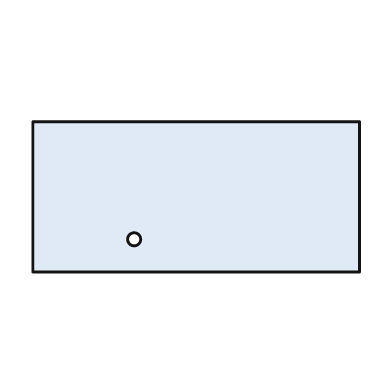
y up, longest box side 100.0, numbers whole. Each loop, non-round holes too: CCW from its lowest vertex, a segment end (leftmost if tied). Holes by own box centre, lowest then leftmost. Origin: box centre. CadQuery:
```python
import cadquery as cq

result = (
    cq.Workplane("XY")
    .moveTo(-50.0, -23.0)
    .lineTo(50.0, -23.0)
    .lineTo(50.0, 23.0)
    .lineTo(-50.0, 23.0)
    .close()
    .moveTo(-19.0, -13.0)
    .circle(2.0)
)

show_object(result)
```